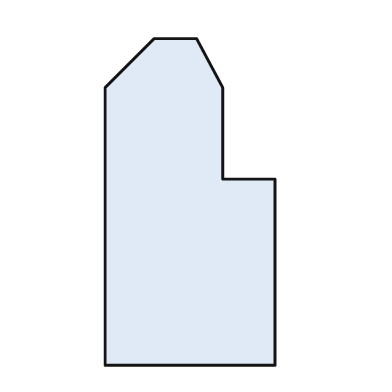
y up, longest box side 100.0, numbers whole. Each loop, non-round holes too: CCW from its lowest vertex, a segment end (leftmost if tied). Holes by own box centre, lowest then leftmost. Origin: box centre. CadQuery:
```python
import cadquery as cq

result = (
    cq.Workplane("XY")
    .moveTo(-26.0, -50.0)
    .lineTo(26.0, -50.0)
    .lineTo(26.0, 7.0)
    .lineTo(10.0, 7.0)
    .lineTo(10.0, 35.0)
    .lineTo(2.0, 50.0)
    .lineTo(-11.0, 50.0)
    .lineTo(-26.0, 35.0)
    .close()
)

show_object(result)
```